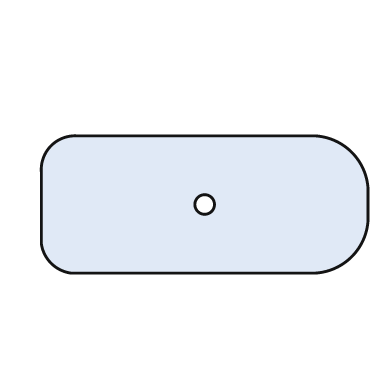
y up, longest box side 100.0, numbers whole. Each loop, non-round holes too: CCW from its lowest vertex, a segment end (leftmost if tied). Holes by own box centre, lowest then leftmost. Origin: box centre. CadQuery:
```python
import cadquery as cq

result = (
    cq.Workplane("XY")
    .moveTo(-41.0, -21.0)
    .lineTo(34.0, -21.0)
    .threePointArc((45.0, -16.0), (50.0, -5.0))
    .lineTo(50.0, 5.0)
    .threePointArc((45.0, 16.0), (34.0, 21.0))
    .lineTo(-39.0, 21.0)
    .threePointArc((-47.0, 18.0), (-50.0, 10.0))
    .lineTo(-50.0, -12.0)
    .threePointArc((-47.0, -18.0), (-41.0, -21.0))
    .close()
    .moveTo(0.0, 0.0)
    .circle(3.0)
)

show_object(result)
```